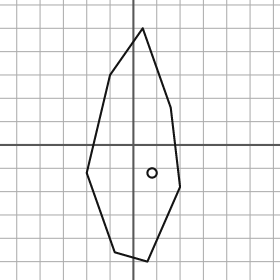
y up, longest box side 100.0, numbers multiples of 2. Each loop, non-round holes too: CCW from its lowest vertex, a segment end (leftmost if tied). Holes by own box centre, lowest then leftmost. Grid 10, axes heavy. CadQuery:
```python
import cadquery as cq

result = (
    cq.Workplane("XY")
    .moveTo(6.0, -50.0)
    .lineTo(20.0, -18.0)
    .lineTo(16.0, 16.0)
    .lineTo(4.0, 50.0)
    .lineTo(-10.0, 30.0)
    .lineTo(-20.0, -12.0)
    .lineTo(-8.0, -46.0)
    .close()
    .moveTo(8.0, -12.0)
    .circle(2.0)
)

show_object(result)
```